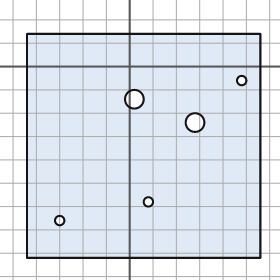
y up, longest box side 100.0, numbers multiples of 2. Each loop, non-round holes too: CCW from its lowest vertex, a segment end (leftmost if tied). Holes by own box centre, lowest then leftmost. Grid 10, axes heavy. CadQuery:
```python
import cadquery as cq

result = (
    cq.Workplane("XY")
    .moveTo(-44.0, -82.0)
    .lineTo(56.0, -82.0)
    .lineTo(56.0, 14.0)
    .lineTo(-44.0, 14.0)
    .close()
    .moveTo(-30.0, -66.0)
    .circle(2.0)
    .moveTo(8.0, -58.0)
    .circle(2.0)
    .moveTo(28.0, -24.0)
    .circle(4.0)
    .moveTo(2.0, -14.0)
    .circle(4.0)
    .moveTo(48.0, -6.0)
    .circle(2.0)
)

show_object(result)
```